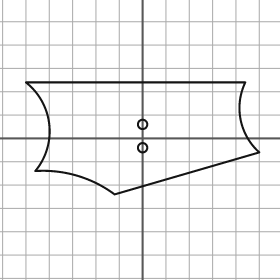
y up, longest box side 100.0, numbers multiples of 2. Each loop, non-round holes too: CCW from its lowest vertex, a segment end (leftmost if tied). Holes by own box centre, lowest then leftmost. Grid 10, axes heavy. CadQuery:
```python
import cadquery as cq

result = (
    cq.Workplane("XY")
    .moveTo(-12.0, -24.0)
    .lineTo(50.0, -6.0)
    .threePointArc((42.0, 8.0), (44.0, 24.0))
    .lineTo(-50.0, 24.0)
    .threePointArc((-40.0, 6.0), (-46.0, -14.0))
    .threePointArc((-28.0, -16.0), (-12.0, -24.0))
    .close()
    .moveTo(0.0, -4.0)
    .circle(2.0)
    .moveTo(0.0, 6.0)
    .circle(2.0)
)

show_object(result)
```